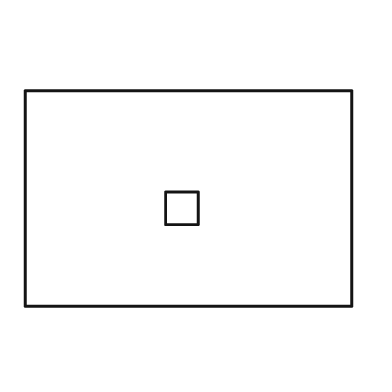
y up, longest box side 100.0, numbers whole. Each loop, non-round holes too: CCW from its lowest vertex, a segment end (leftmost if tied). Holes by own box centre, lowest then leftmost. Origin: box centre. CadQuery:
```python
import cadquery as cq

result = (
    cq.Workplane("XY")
    .moveTo(-50.0, -33.0)
    .lineTo(50.0, -33.0)
    .lineTo(50.0, 33.0)
    .lineTo(-50.0, 33.0)
    .close()
    .moveTo(-7.0, -8.0)
    .lineTo(3.0, -8.0)
    .lineTo(3.0, 2.0)
    .lineTo(-7.0, 2.0)
    .close()
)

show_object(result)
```